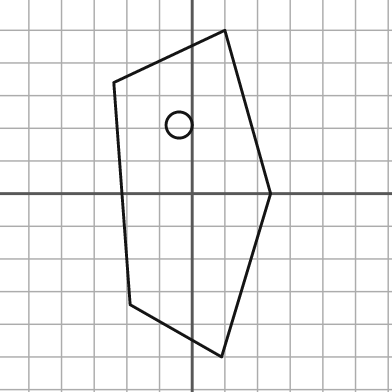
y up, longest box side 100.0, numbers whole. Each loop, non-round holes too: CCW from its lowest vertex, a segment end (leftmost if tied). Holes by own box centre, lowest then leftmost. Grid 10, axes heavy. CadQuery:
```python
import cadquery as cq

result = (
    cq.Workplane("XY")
    .moveTo(9.0, -50.0)
    .lineTo(24.0, 0.0)
    .lineTo(10.0, 50.0)
    .lineTo(-24.0, 34.0)
    .lineTo(-19.0, -34.0)
    .close()
    .moveTo(-4.0, 21.0)
    .circle(4.0)
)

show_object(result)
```